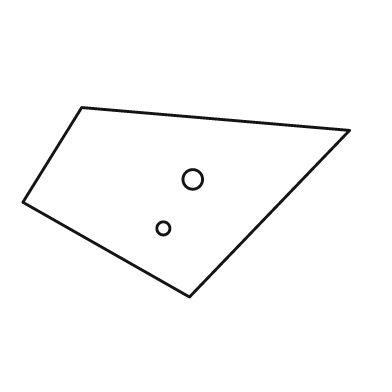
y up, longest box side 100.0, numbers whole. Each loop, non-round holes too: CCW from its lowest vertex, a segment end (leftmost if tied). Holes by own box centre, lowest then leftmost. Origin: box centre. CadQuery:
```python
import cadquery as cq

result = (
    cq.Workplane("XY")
    .moveTo(1.0, -29.0)
    .lineTo(50.0, 22.0)
    .lineTo(-32.0, 29.0)
    .lineTo(-50.0, 0.0)
    .close()
    .moveTo(-7.0, -8.0)
    .circle(2.0)
    .moveTo(2.0, 7.0)
    .circle(3.0)
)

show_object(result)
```